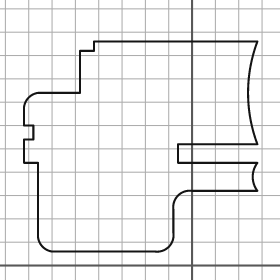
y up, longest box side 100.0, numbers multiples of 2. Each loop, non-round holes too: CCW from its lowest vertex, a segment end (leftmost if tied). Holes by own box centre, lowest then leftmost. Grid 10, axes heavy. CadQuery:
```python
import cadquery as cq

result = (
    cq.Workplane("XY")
    .moveTo(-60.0, 6.0)
    .lineTo(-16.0, 6.0)
    .threePointArc((-10.0, 8.0), (-8.0, 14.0))
    .lineTo(-8.0, 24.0)
    .threePointArc((-6.0, 30.0), (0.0, 32.0))
    .lineTo(28.0, 32.0)
    .threePointArc((26.0, 38.0), (28.0, 44.0))
    .lineTo(-6.0, 44.0)
    .lineTo(-6.0, 52.0)
    .lineTo(28.0, 52.0)
    .threePointArc((24.0, 74.0), (28.0, 96.0))
    .lineTo(-42.0, 96.0)
    .lineTo(-42.0, 92.0)
    .lineTo(-48.0, 92.0)
    .lineTo(-48.0, 74.0)
    .lineTo(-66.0, 74.0)
    .threePointArc((-70.0, 72.0), (-72.0, 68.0))
    .lineTo(-72.0, 60.0)
    .lineTo(-68.0, 60.0)
    .lineTo(-68.0, 54.0)
    .lineTo(-72.0, 54.0)
    .lineTo(-72.0, 44.0)
    .lineTo(-66.0, 44.0)
    .lineTo(-66.0, 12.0)
    .threePointArc((-64.0, 8.0), (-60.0, 6.0))
    .close()
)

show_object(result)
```